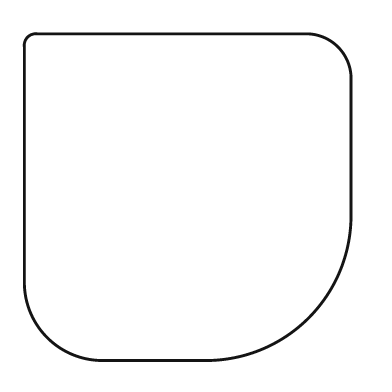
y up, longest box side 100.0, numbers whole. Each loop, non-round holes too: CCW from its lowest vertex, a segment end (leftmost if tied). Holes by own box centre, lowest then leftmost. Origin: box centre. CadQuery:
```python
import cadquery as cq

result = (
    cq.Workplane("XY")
    .moveTo(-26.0, -50.0)
    .lineTo(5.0, -50.0)
    .threePointArc((37.0, -37.0), (50.0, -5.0))
    .lineTo(50.0, 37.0)
    .threePointArc((46.0, 46.0), (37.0, 50.0))
    .lineTo(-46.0, 50.0)
    .threePointArc((-49.0, 49.0), (-50.0, 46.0))
    .lineTo(-50.0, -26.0)
    .threePointArc((-43.0, -43.0), (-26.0, -50.0))
    .close()
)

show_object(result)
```